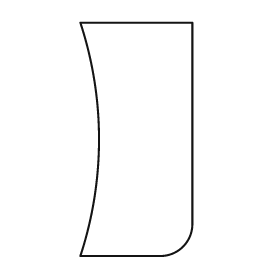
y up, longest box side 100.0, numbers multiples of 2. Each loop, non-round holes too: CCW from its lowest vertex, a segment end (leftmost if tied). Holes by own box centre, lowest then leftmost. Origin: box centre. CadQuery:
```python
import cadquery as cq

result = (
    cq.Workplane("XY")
    .moveTo(-24.0, -50.0)
    .lineTo(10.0, -50.0)
    .threePointArc((20.0, -46.0), (24.0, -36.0))
    .lineTo(24.0, 50.0)
    .lineTo(-24.0, 50.0)
    .threePointArc((-16.0, 0.0), (-24.0, -50.0))
    .close()
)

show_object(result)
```